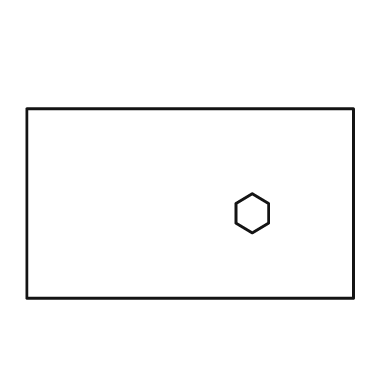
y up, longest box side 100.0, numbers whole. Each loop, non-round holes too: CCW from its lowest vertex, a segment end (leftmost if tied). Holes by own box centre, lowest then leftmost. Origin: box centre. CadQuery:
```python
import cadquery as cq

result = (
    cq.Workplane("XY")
    .moveTo(-50.0, -29.0)
    .lineTo(50.0, -29.0)
    .lineTo(50.0, 29.0)
    .lineTo(-50.0, 29.0)
    .close()
    .moveTo(19.0, -9.0)
    .lineTo(24.0, -6.0)
    .lineTo(24.0, 0.0)
    .lineTo(19.0, 3.0)
    .lineTo(14.0, 0.0)
    .lineTo(14.0, -6.0)
    .close()
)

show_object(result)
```